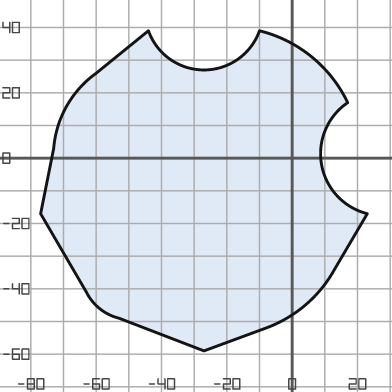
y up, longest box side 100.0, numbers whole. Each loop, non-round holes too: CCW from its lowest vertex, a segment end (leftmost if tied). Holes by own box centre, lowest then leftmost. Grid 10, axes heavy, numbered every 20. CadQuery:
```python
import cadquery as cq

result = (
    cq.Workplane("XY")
    .moveTo(-27.0, -59.0)
    .lineTo(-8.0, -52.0)
    .threePointArc((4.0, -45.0), (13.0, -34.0))
    .lineTo(23.0, -17.0)
    .threePointArc((9.0, -2.0), (17.0, 17.0))
    .threePointArc((6.0, 31.0), (-10.0, 39.0))
    .threePointArc((-27.0, 27.0), (-44.0, 39.0))
    .lineTo(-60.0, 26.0)
    .threePointArc((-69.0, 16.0), (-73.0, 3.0))
    .lineTo(-77.0, -17.0)
    .lineTo(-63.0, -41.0)
    .threePointArc((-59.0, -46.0), (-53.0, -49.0))
    .close()
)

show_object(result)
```